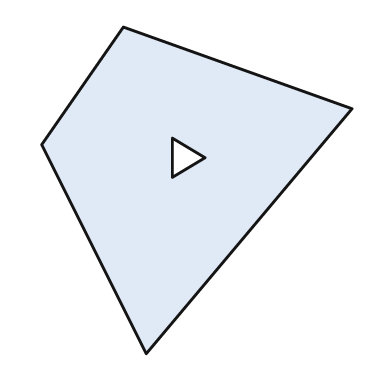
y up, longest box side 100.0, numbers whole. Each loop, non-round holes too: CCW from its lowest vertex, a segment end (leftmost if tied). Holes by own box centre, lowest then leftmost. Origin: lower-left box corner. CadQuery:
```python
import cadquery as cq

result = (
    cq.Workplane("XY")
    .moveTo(32.0, 0.0)
    .lineTo(95.0, 75.0)
    .lineTo(25.0, 100.0)
    .lineTo(0.0, 64.0)
    .close()
    .moveTo(40.0, 54.0)
    .lineTo(50.0, 60.0)
    .lineTo(40.0, 66.0)
    .close()
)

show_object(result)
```